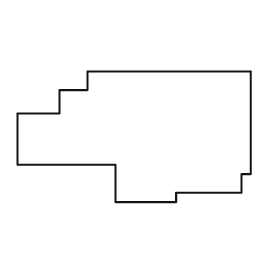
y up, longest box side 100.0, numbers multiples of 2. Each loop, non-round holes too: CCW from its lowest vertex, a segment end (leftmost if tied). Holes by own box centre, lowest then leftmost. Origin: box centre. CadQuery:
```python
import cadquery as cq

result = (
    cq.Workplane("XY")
    .moveTo(-8.0, -28.0)
    .lineTo(18.0, -28.0)
    .lineTo(18.0, -24.0)
    .lineTo(46.0, -24.0)
    .lineTo(46.0, -16.0)
    .lineTo(50.0, -16.0)
    .lineTo(50.0, 28.0)
    .lineTo(-20.0, 28.0)
    .lineTo(-20.0, 20.0)
    .lineTo(-32.0, 20.0)
    .lineTo(-32.0, 10.0)
    .lineTo(-50.0, 10.0)
    .lineTo(-50.0, -12.0)
    .lineTo(-8.0, -12.0)
    .close()
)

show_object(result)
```